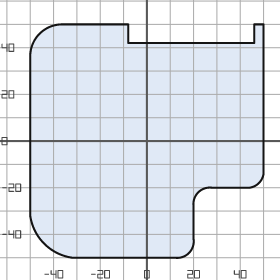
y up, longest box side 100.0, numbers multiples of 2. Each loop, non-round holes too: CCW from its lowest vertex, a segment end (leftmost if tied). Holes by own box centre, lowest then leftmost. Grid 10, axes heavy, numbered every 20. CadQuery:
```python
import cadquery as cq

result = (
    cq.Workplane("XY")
    .moveTo(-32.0, -50.0)
    .lineTo(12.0, -50.0)
    .threePointArc((18.0, -48.0), (20.0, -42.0))
    .lineTo(20.0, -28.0)
    .threePointArc((22.0, -22.0), (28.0, -20.0))
    .lineTo(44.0, -20.0)
    .threePointArc((48.0, -18.0), (50.0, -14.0))
    .lineTo(50.0, 50.0)
    .lineTo(46.0, 50.0)
    .lineTo(46.0, 42.0)
    .lineTo(-8.0, 42.0)
    .lineTo(-8.0, 50.0)
    .lineTo(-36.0, 50.0)
    .threePointArc((-46.0, 46.0), (-50.0, 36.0))
    .lineTo(-50.0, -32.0)
    .threePointArc((-44.0, -44.0), (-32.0, -50.0))
    .close()
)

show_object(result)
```